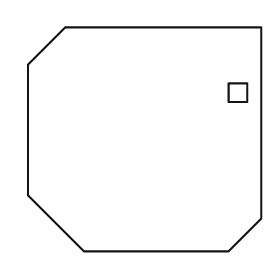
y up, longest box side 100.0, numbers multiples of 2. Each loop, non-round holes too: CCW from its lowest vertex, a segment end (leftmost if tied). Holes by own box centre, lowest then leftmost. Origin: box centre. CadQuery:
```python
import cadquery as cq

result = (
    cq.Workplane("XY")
    .moveTo(-26.0, -48.0)
    .lineTo(36.0, -48.0)
    .lineTo(50.0, -34.0)
    .lineTo(50.0, 48.0)
    .lineTo(-34.0, 48.0)
    .lineTo(-50.0, 32.0)
    .lineTo(-50.0, -24.0)
    .close()
    .moveTo(36.0, 16.0)
    .lineTo(44.0, 16.0)
    .lineTo(44.0, 24.0)
    .lineTo(36.0, 24.0)
    .close()
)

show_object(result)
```